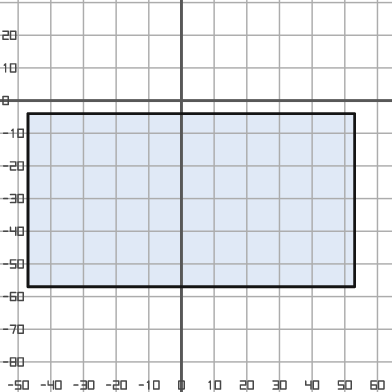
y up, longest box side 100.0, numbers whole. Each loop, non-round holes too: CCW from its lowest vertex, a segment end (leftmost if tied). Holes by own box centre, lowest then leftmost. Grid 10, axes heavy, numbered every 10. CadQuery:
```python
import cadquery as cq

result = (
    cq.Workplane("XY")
    .moveTo(-47.0, -57.0)
    .lineTo(53.0, -57.0)
    .lineTo(53.0, -4.0)
    .lineTo(-47.0, -4.0)
    .close()
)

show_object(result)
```